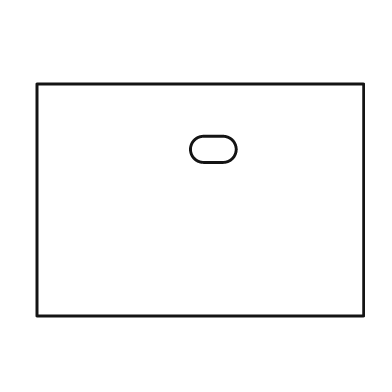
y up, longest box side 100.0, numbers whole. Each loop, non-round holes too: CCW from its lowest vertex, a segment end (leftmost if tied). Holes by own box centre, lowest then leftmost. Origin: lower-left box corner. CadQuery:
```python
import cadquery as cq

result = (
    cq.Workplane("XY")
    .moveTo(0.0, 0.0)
    .lineTo(100.0, 0.0)
    .lineTo(100.0, 71.0)
    .lineTo(0.0, 71.0)
    .close()
    .moveTo(51.0, 47.0)
    .lineTo(57.0, 47.0)
    .threePointArc((61.0, 51.0), (57.0, 55.0))
    .lineTo(51.0, 55.0)
    .threePointArc((47.0, 51.0), (51.0, 47.0))
    .close()
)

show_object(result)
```